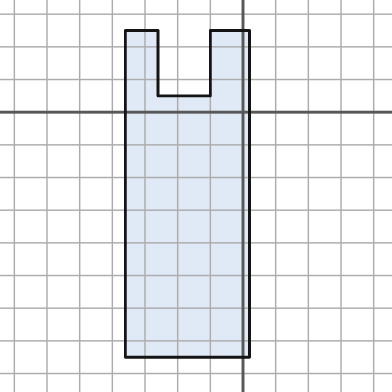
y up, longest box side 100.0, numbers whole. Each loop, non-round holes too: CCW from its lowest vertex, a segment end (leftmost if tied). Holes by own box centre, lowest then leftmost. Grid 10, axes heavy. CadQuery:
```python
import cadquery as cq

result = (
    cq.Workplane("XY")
    .moveTo(-36.0, -75.0)
    .lineTo(2.0, -75.0)
    .lineTo(2.0, 25.0)
    .lineTo(-10.0, 25.0)
    .lineTo(-10.0, 5.0)
    .lineTo(-26.0, 5.0)
    .lineTo(-26.0, 25.0)
    .lineTo(-36.0, 25.0)
    .close()
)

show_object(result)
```